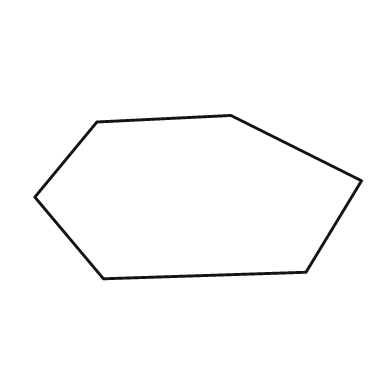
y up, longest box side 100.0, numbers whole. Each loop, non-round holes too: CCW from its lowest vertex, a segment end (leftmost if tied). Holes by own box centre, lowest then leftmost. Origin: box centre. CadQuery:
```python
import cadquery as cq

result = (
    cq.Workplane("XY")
    .moveTo(-29.0, -25.0)
    .lineTo(33.0, -23.0)
    .lineTo(50.0, 5.0)
    .lineTo(10.0, 25.0)
    .lineTo(-31.0, 23.0)
    .lineTo(-50.0, 0.0)
    .close()
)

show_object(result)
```